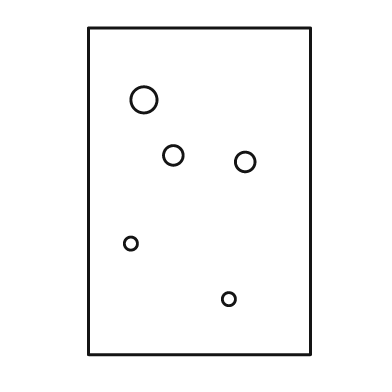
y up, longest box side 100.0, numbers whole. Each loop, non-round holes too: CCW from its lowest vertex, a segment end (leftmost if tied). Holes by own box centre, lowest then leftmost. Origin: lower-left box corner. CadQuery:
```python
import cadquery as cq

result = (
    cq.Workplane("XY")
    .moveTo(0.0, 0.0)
    .lineTo(68.0, 0.0)
    .lineTo(68.0, 100.0)
    .lineTo(0.0, 100.0)
    .close()
    .moveTo(43.0, 17.0)
    .circle(2.0)
    .moveTo(13.0, 34.0)
    .circle(2.0)
    .moveTo(48.0, 59.0)
    .circle(3.0)
    .moveTo(26.0, 61.0)
    .circle(3.0)
    .moveTo(17.0, 78.0)
    .circle(4.0)
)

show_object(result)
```